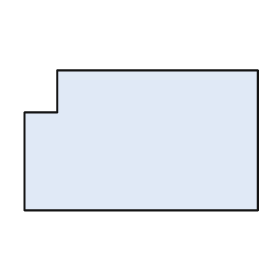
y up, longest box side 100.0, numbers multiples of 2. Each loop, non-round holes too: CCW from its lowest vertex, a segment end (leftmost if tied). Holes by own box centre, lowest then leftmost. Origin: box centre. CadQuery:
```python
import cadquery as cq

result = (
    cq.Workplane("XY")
    .moveTo(-50.0, -30.0)
    .lineTo(50.0, -30.0)
    .lineTo(50.0, 30.0)
    .lineTo(-36.0, 30.0)
    .lineTo(-36.0, 12.0)
    .lineTo(-50.0, 12.0)
    .close()
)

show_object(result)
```